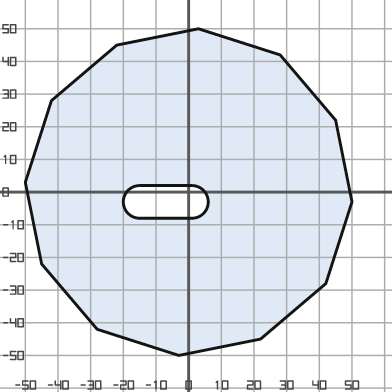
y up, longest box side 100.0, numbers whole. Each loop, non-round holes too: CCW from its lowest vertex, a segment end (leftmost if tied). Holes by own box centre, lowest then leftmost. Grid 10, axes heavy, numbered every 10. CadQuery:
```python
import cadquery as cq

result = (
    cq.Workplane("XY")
    .moveTo(-3.0, -50.0)
    .lineTo(22.0, -45.0)
    .lineTo(42.0, -28.0)
    .lineTo(50.0, -3.0)
    .lineTo(45.0, 22.0)
    .lineTo(28.0, 42.0)
    .lineTo(3.0, 50.0)
    .lineTo(-22.0, 45.0)
    .lineTo(-42.0, 28.0)
    .lineTo(-50.0, 3.0)
    .lineTo(-45.0, -22.0)
    .lineTo(-28.0, -42.0)
    .close()
    .moveTo(-15.0, -8.0)
    .lineTo(1.0, -8.0)
    .threePointArc((6.0, -3.0), (1.0, 2.0))
    .lineTo(-15.0, 2.0)
    .threePointArc((-20.0, -3.0), (-15.0, -8.0))
    .close()
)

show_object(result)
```